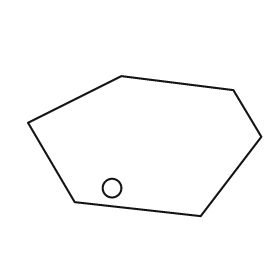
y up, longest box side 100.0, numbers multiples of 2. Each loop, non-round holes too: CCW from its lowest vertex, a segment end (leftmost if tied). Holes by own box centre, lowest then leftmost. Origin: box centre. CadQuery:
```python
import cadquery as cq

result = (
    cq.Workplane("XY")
    .moveTo(24.0, -30.0)
    .lineTo(50.0, 4.0)
    .lineTo(38.0, 24.0)
    .lineTo(-10.0, 30.0)
    .lineTo(-50.0, 10.0)
    .lineTo(-30.0, -24.0)
    .close()
    .moveTo(-14.0, -18.0)
    .circle(4.0)
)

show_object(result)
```